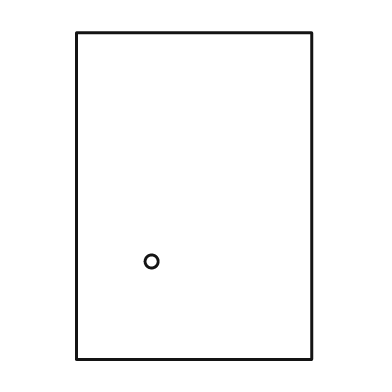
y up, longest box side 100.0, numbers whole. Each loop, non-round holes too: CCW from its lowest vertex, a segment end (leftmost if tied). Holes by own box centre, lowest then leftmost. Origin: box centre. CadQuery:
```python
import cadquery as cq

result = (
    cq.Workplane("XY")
    .moveTo(-36.0, -50.0)
    .lineTo(36.0, -50.0)
    .lineTo(36.0, 50.0)
    .lineTo(-36.0, 50.0)
    .close()
    .moveTo(-13.0, -20.0)
    .circle(2.0)
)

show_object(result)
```